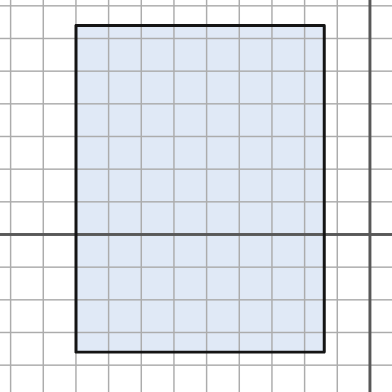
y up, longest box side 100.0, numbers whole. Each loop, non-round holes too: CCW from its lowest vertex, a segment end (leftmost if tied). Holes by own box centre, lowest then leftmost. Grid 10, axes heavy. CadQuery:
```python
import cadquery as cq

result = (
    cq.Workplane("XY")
    .moveTo(-90.0, -36.0)
    .lineTo(-14.0, -36.0)
    .lineTo(-14.0, 64.0)
    .lineTo(-90.0, 64.0)
    .close()
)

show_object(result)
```